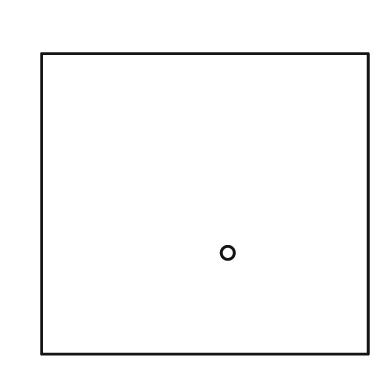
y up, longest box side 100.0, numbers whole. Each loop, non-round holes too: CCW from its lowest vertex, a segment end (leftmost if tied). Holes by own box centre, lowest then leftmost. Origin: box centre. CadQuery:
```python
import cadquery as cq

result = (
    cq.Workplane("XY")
    .moveTo(-50.0, -46.0)
    .lineTo(50.0, -46.0)
    .lineTo(50.0, 46.0)
    .lineTo(-50.0, 46.0)
    .close()
    .moveTo(7.0, -15.0)
    .circle(2.0)
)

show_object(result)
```